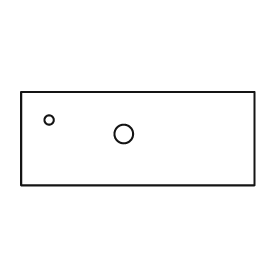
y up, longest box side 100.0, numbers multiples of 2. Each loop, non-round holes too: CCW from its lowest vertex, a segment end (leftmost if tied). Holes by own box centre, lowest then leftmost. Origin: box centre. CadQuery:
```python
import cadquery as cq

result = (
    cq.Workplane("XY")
    .moveTo(-50.0, -20.0)
    .lineTo(50.0, -20.0)
    .lineTo(50.0, 20.0)
    .lineTo(-50.0, 20.0)
    .close()
    .moveTo(-6.0, 2.0)
    .circle(4.0)
    .moveTo(-38.0, 8.0)
    .circle(2.0)
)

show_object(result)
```